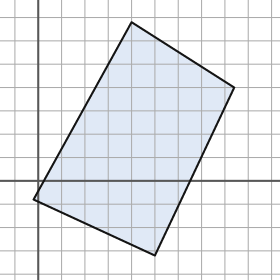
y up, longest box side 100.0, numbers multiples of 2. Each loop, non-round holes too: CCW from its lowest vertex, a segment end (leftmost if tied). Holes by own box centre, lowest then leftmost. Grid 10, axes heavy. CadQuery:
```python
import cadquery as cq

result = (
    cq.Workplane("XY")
    .moveTo(50.0, -32.0)
    .lineTo(84.0, 40.0)
    .lineTo(40.0, 68.0)
    .lineTo(-2.0, -8.0)
    .close()
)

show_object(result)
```